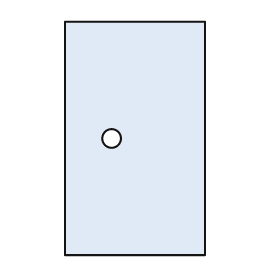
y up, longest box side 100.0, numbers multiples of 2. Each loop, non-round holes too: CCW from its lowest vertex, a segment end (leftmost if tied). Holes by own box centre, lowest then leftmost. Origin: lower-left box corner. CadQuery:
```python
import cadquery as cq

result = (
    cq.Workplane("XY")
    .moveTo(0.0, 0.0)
    .lineTo(60.0, 0.0)
    .lineTo(60.0, 100.0)
    .lineTo(0.0, 100.0)
    .close()
    .moveTo(20.0, 50.0)
    .circle(4.0)
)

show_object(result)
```